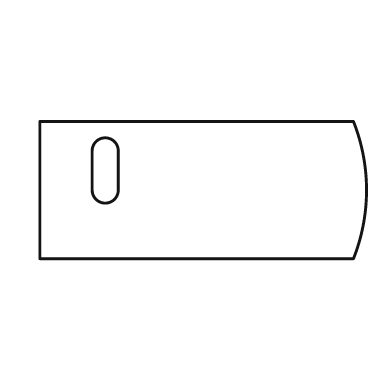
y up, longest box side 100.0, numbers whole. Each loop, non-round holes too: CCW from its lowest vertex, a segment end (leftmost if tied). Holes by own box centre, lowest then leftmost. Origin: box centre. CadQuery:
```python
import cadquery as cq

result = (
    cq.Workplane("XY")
    .moveTo(-50.0, -21.0)
    .lineTo(46.0, -21.0)
    .threePointArc((50.0, 0.0), (46.0, 21.0))
    .lineTo(-50.0, 21.0)
    .close()
    .moveTo(-34.0, 0.0)
    .threePointArc((-30.0, -4.0), (-26.0, 0.0))
    .lineTo(-26.0, 12.0)
    .threePointArc((-30.0, 16.0), (-34.0, 12.0))
    .close()
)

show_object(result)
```